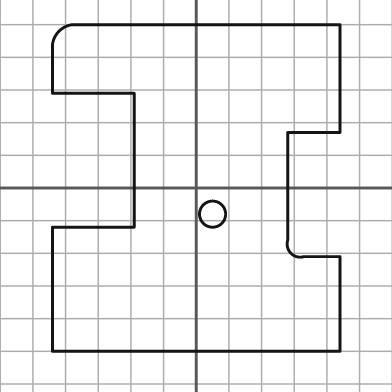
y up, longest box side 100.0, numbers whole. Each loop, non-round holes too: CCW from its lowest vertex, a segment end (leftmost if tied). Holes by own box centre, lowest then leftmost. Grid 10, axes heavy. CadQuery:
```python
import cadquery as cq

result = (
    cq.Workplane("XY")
    .moveTo(-44.0, -50.0)
    .lineTo(44.0, -50.0)
    .lineTo(44.0, -21.0)
    .lineTo(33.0, -21.0)
    .threePointArc((29.0, -20.0), (28.0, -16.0))
    .lineTo(28.0, 17.0)
    .lineTo(44.0, 17.0)
    .lineTo(44.0, 50.0)
    .lineTo(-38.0, 50.0)
    .threePointArc((-42.0, 48.0), (-44.0, 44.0))
    .lineTo(-44.0, 29.0)
    .lineTo(-19.0, 29.0)
    .lineTo(-19.0, -12.0)
    .lineTo(-44.0, -12.0)
    .close()
    .moveTo(5.0, -8.0)
    .circle(4.0)
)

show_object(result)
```